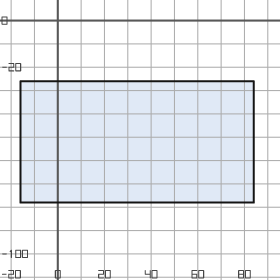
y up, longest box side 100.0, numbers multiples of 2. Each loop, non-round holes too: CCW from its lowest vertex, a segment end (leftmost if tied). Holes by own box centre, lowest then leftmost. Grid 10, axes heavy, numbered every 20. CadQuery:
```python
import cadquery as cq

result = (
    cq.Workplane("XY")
    .moveTo(-16.0, -78.0)
    .lineTo(84.0, -78.0)
    .lineTo(84.0, -26.0)
    .lineTo(-16.0, -26.0)
    .close()
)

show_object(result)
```